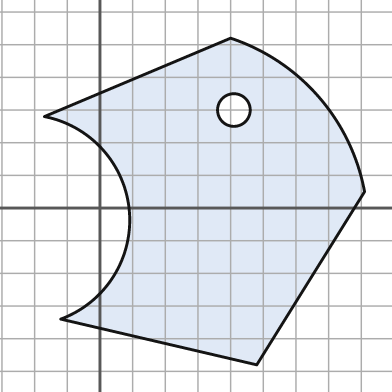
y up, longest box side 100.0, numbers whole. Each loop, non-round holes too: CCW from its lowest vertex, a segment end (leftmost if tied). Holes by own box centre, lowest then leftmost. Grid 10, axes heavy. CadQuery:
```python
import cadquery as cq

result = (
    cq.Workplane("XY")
    .moveTo(48.0, -48.0)
    .lineTo(81.0, 5.0)
    .threePointArc((67.0, 34.0), (40.0, 52.0))
    .lineTo(-17.0, 28.0)
    .threePointArc((9.0, -1.0), (-12.0, -34.0))
    .close()
    .moveTo(41.0, 30.0)
    .circle(5.0)
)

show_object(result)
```